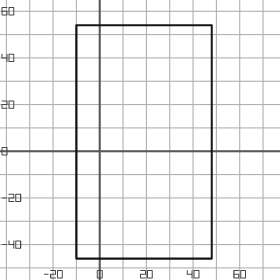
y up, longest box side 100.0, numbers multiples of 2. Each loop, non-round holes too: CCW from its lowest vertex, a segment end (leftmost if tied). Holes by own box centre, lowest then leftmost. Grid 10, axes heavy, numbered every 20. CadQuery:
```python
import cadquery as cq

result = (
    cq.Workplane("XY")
    .moveTo(-10.0, -46.0)
    .lineTo(48.0, -46.0)
    .lineTo(48.0, 54.0)
    .lineTo(-10.0, 54.0)
    .close()
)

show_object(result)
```